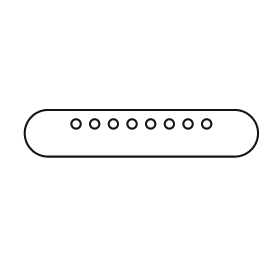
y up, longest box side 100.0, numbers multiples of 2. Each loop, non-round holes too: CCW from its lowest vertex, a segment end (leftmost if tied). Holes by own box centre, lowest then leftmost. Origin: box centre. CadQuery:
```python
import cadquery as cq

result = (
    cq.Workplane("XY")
    .moveTo(-40.0, -10.0)
    .lineTo(40.0, -10.0)
    .threePointArc((50.0, 0.0), (40.0, 10.0))
    .lineTo(-40.0, 10.0)
    .threePointArc((-50.0, 0.0), (-40.0, -10.0))
    .close()
    .moveTo(-28.0, 4.0)
    .circle(2.0)
    .moveTo(-20.0, 4.0)
    .circle(2.0)
    .moveTo(-12.0, 4.0)
    .circle(2.0)
    .moveTo(-4.0, 4.0)
    .circle(2.0)
    .moveTo(4.0, 4.0)
    .circle(2.0)
    .moveTo(12.0, 4.0)
    .circle(2.0)
    .moveTo(20.0, 4.0)
    .circle(2.0)
    .moveTo(28.0, 4.0)
    .circle(2.0)
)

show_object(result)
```